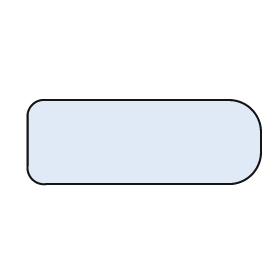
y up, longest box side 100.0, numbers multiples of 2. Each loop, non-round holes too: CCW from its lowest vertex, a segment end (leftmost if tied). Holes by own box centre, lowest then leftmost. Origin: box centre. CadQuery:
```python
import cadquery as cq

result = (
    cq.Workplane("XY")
    .moveTo(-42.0, -18.0)
    .lineTo(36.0, -18.0)
    .threePointArc((46.0, -14.0), (50.0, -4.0))
    .lineTo(50.0, 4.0)
    .threePointArc((46.0, 14.0), (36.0, 18.0))
    .lineTo(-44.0, 18.0)
    .threePointArc((-48.0, 16.0), (-50.0, 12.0))
    .lineTo(-50.0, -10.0)
    .threePointArc((-48.0, -16.0), (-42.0, -18.0))
    .close()
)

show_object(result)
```